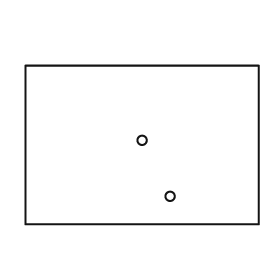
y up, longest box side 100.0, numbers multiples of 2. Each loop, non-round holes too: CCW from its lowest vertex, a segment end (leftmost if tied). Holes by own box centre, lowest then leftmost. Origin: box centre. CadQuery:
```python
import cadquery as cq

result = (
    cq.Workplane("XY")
    .moveTo(-50.0, -34.0)
    .lineTo(50.0, -34.0)
    .lineTo(50.0, 34.0)
    .lineTo(-50.0, 34.0)
    .close()
    .moveTo(12.0, -22.0)
    .circle(2.0)
    .moveTo(0.0, 2.0)
    .circle(2.0)
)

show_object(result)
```